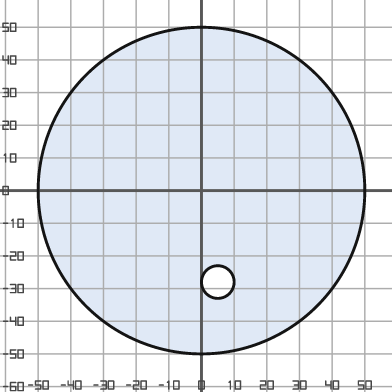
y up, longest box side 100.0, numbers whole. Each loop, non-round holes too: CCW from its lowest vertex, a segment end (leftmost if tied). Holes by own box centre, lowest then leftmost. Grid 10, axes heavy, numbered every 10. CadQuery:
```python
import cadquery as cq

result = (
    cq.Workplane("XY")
    .moveTo(0.0, 0.0)
    .circle(50.0)
    .moveTo(5.0, -28.0)
    .circle(5.0)
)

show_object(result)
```